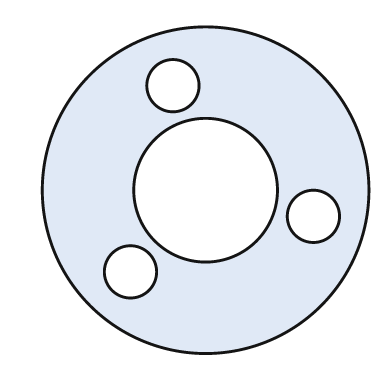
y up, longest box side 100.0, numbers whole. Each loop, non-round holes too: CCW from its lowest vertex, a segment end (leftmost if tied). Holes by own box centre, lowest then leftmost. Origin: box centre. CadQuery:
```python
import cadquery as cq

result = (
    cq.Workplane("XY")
    .moveTo(0.0, 0.0)
    .circle(50.0)
    .moveTo(-23.0, -25.0)
    .circle(8.0)
    .moveTo(33.0, -8.0)
    .circle(8.0)
    .moveTo(0.0, 0.0)
    .circle(22.0)
    .moveTo(-10.0, 32.0)
    .circle(8.0)
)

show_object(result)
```